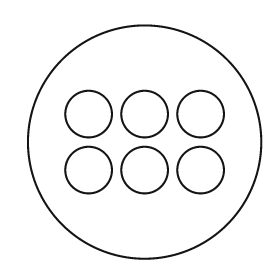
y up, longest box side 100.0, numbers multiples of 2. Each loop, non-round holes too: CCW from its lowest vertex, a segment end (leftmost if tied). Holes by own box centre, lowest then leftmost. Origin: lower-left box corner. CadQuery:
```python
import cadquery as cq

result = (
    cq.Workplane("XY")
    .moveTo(50.0, 50.0)
    .circle(50.0)
    .moveTo(26.0, 38.0)
    .circle(10.0)
    .moveTo(50.0, 38.0)
    .circle(10.0)
    .moveTo(74.0, 38.0)
    .circle(10.0)
    .moveTo(26.0, 62.0)
    .circle(10.0)
    .moveTo(50.0, 62.0)
    .circle(10.0)
    .moveTo(74.0, 62.0)
    .circle(10.0)
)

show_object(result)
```